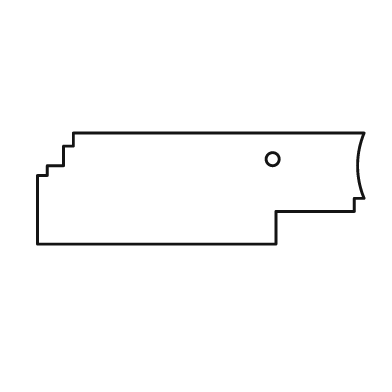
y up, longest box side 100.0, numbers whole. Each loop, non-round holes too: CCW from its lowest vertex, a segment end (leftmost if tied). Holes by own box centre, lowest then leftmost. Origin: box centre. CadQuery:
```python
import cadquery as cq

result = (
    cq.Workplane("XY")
    .moveTo(-50.0, -17.0)
    .lineTo(23.0, -17.0)
    .lineTo(23.0, -7.0)
    .lineTo(47.0, -7.0)
    .lineTo(47.0, -3.0)
    .lineTo(50.0, -3.0)
    .threePointArc((48.0, 7.0), (50.0, 17.0))
    .lineTo(-39.0, 17.0)
    .lineTo(-39.0, 13.0)
    .lineTo(-42.0, 13.0)
    .lineTo(-42.0, 7.0)
    .lineTo(-47.0, 7.0)
    .lineTo(-47.0, 4.0)
    .lineTo(-50.0, 4.0)
    .close()
    .moveTo(22.0, 9.0)
    .circle(2.0)
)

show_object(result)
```